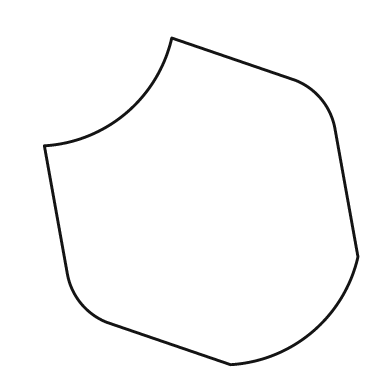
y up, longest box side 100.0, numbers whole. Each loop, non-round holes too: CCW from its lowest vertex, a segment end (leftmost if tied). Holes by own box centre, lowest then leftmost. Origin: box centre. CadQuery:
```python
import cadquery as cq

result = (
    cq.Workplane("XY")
    .moveTo(9.0, -50.0)
    .threePointArc((34.0, -40.0), (48.0, -17.0))
    .lineTo(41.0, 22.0)
    .threePointArc((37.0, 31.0), (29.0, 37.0))
    .lineTo(-9.0, 50.0)
    .threePointArc((-23.0, 27.0), (-48.0, 17.0))
    .lineTo(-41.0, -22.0)
    .threePointArc((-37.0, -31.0), (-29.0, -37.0))
    .close()
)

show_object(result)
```